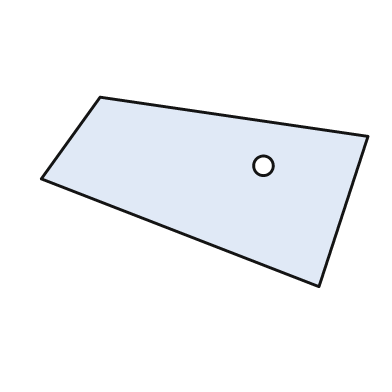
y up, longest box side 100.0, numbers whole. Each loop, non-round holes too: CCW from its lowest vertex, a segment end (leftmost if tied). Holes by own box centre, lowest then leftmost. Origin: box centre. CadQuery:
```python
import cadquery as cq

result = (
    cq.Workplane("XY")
    .moveTo(35.0, -29.0)
    .lineTo(50.0, 17.0)
    .lineTo(-32.0, 29.0)
    .lineTo(-50.0, 4.0)
    .close()
    .moveTo(18.0, 8.0)
    .circle(3.0)
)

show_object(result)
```